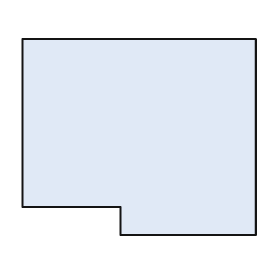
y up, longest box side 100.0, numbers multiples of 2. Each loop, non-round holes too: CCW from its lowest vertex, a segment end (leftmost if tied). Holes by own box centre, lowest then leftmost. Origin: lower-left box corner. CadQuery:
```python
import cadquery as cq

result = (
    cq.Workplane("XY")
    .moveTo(42.0, 0.0)
    .lineTo(100.0, 0.0)
    .lineTo(100.0, 84.0)
    .lineTo(0.0, 84.0)
    .lineTo(0.0, 12.0)
    .lineTo(42.0, 12.0)
    .close()
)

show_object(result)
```